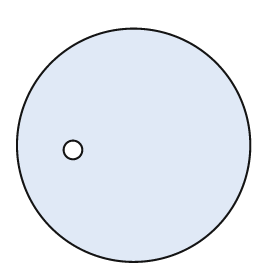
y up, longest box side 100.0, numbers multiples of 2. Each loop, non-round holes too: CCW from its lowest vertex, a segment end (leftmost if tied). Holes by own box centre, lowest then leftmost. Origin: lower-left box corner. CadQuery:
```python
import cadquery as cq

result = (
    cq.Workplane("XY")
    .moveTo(50.0, 50.0)
    .circle(50.0)
    .moveTo(24.0, 48.0)
    .circle(4.0)
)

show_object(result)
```